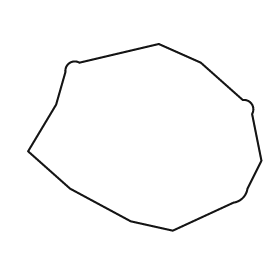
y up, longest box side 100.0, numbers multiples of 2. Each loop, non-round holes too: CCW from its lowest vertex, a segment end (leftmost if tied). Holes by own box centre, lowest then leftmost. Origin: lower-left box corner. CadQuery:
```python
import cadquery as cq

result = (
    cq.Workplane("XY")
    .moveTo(62.0, 0.0)
    .lineTo(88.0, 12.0)
    .threePointArc((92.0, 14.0), (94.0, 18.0))
    .lineTo(100.0, 30.0)
    .lineTo(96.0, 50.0)
    .threePointArc((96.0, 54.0), (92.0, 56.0))
    .lineTo(74.0, 72.0)
    .lineTo(56.0, 80.0)
    .lineTo(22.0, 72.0)
    .threePointArc((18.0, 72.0), (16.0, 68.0))
    .lineTo(12.0, 54.0)
    .lineTo(0.0, 34.0)
    .lineTo(18.0, 18.0)
    .lineTo(44.0, 4.0)
    .close()
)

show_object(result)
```